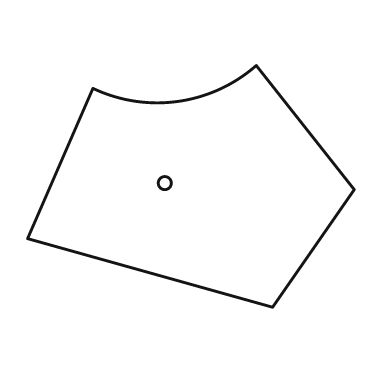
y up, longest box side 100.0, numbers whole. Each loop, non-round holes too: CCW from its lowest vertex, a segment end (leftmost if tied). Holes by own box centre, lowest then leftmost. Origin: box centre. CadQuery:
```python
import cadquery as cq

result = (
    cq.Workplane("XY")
    .moveTo(25.0, -37.0)
    .lineTo(50.0, -1.0)
    .lineTo(20.0, 37.0)
    .threePointArc((-4.0, 26.0), (-30.0, 30.0))
    .lineTo(-50.0, -16.0)
    .close()
    .moveTo(-8.0, 1.0)
    .circle(2.0)
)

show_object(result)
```